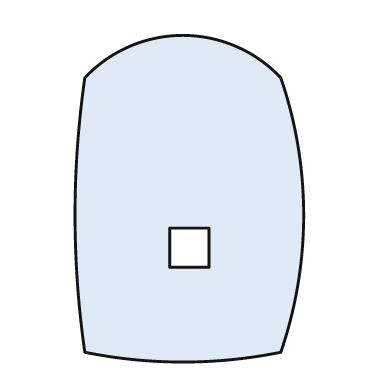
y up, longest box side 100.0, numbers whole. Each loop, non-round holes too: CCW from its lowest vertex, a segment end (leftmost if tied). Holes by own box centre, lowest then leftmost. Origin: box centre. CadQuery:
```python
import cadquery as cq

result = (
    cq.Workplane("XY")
    .moveTo(-32.0, -47.0)
    .threePointArc((-2.0, -50.0), (28.0, -47.0))
    .threePointArc((35.0, -5.0), (28.0, 37.0))
    .threePointArc((-2.0, 50.0), (-32.0, 37.0))
    .threePointArc((-35.0, -5.0), (-32.0, -47.0))
    .close()
    .moveTo(-6.0, -21.0)
    .lineTo(6.0, -21.0)
    .lineTo(6.0, -9.0)
    .lineTo(-6.0, -9.0)
    .close()
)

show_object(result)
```